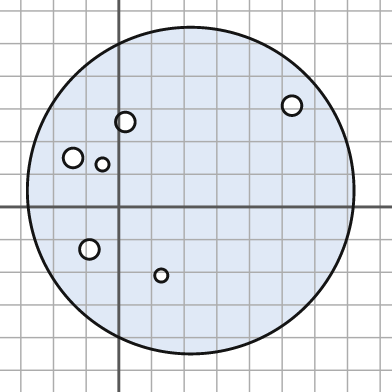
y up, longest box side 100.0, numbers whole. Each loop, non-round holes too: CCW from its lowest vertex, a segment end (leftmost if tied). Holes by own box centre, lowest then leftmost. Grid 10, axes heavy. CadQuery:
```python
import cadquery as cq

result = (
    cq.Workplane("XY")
    .moveTo(22.0, 5.0)
    .circle(50.0)
    .moveTo(13.0, -21.0)
    .circle(2.0)
    .moveTo(-9.0, -13.0)
    .circle(3.0)
    .moveTo(-5.0, 13.0)
    .circle(2.0)
    .moveTo(-14.0, 15.0)
    .circle(3.0)
    .moveTo(2.0, 26.0)
    .circle(3.0)
    .moveTo(53.0, 31.0)
    .circle(3.0)
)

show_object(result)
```